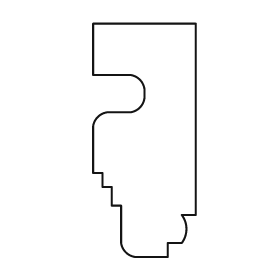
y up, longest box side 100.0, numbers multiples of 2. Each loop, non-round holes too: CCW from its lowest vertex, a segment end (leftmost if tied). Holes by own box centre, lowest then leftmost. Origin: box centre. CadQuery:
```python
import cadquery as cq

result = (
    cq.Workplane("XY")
    .moveTo(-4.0, -50.0)
    .lineTo(10.0, -50.0)
    .lineTo(10.0, -44.0)
    .lineTo(16.0, -44.0)
    .threePointArc((18.0, -38.0), (16.0, -32.0))
    .lineTo(22.0, -32.0)
    .lineTo(22.0, 50.0)
    .lineTo(-22.0, 50.0)
    .lineTo(-22.0, 28.0)
    .lineTo(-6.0, 28.0)
    .threePointArc((-2.0, 26.0), (0.0, 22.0))
    .lineTo(0.0, 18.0)
    .threePointArc((-2.0, 14.0), (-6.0, 12.0))
    .lineTo(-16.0, 12.0)
    .threePointArc((-20.0, 10.0), (-22.0, 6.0))
    .lineTo(-22.0, -14.0)
    .lineTo(-18.0, -14.0)
    .lineTo(-18.0, -20.0)
    .lineTo(-14.0, -20.0)
    .lineTo(-14.0, -28.0)
    .lineTo(-10.0, -28.0)
    .lineTo(-10.0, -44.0)
    .threePointArc((-8.0, -48.0), (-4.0, -50.0))
    .close()
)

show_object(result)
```